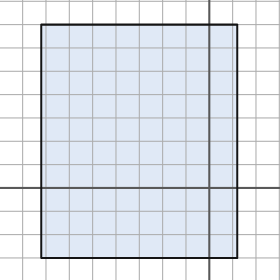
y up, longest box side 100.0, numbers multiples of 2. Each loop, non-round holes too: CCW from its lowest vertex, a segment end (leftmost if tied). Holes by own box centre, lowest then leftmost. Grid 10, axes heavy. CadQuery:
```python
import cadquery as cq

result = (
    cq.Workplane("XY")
    .moveTo(-72.0, -30.0)
    .lineTo(12.0, -30.0)
    .lineTo(12.0, 70.0)
    .lineTo(-72.0, 70.0)
    .close()
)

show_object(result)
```